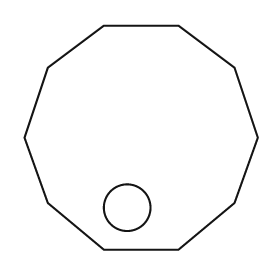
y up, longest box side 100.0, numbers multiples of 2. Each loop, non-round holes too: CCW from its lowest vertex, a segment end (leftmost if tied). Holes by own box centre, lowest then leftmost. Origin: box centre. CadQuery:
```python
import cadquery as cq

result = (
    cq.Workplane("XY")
    .moveTo(-16.0, -48.0)
    .lineTo(16.0, -48.0)
    .lineTo(40.0, -28.0)
    .lineTo(50.0, 0.0)
    .lineTo(40.0, 30.0)
    .lineTo(16.0, 48.0)
    .lineTo(-16.0, 48.0)
    .lineTo(-40.0, 30.0)
    .lineTo(-50.0, 0.0)
    .lineTo(-40.0, -28.0)
    .close()
    .moveTo(-6.0, -30.0)
    .circle(10.0)
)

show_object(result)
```